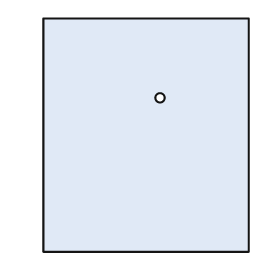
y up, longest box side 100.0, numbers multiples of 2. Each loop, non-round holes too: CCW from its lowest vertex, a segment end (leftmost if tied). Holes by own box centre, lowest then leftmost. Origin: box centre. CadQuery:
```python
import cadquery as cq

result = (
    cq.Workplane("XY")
    .moveTo(-44.0, -50.0)
    .lineTo(44.0, -50.0)
    .lineTo(44.0, 50.0)
    .lineTo(-44.0, 50.0)
    .close()
    .moveTo(6.0, 16.0)
    .circle(2.0)
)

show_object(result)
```